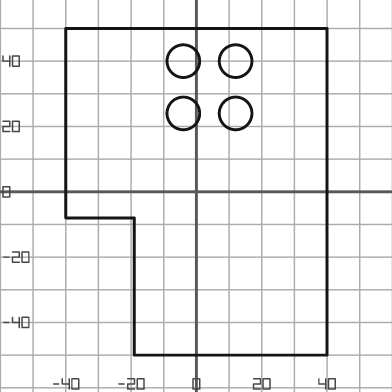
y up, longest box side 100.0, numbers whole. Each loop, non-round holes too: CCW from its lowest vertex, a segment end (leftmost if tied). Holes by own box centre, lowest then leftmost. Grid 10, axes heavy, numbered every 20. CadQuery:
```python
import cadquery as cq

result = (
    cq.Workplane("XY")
    .moveTo(-19.0, -50.0)
    .lineTo(40.0, -50.0)
    .lineTo(40.0, 50.0)
    .lineTo(-40.0, 50.0)
    .lineTo(-40.0, -8.0)
    .lineTo(-19.0, -8.0)
    .close()
    .moveTo(-4.0, 24.0)
    .circle(5.0)
    .moveTo(12.0, 24.0)
    .circle(5.0)
    .moveTo(-4.0, 40.0)
    .circle(5.0)
    .moveTo(12.0, 40.0)
    .circle(5.0)
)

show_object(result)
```